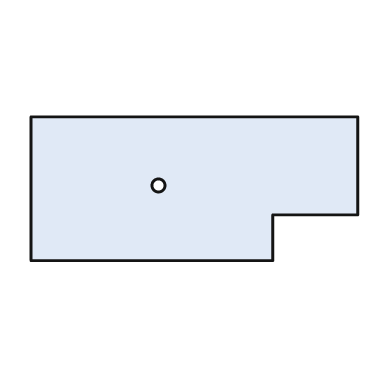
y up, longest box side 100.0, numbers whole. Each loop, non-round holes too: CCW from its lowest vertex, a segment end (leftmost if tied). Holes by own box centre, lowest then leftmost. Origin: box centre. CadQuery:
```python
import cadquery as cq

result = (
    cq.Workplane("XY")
    .moveTo(-50.0, -22.0)
    .lineTo(24.0, -22.0)
    .lineTo(24.0, -8.0)
    .lineTo(50.0, -8.0)
    .lineTo(50.0, 22.0)
    .lineTo(-50.0, 22.0)
    .close()
    .moveTo(-11.0, 1.0)
    .circle(2.0)
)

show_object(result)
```